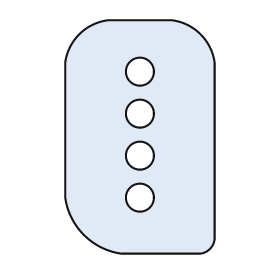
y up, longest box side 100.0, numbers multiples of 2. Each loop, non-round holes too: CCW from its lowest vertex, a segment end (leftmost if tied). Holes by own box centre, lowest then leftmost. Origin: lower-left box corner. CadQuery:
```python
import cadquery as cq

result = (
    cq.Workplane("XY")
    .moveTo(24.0, 0.0)
    .lineTo(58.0, 0.0)
    .threePointArc((62.0, 2.0), (64.0, 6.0))
    .lineTo(64.0, 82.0)
    .threePointArc((58.0, 94.0), (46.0, 100.0))
    .lineTo(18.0, 100.0)
    .threePointArc((6.0, 94.0), (0.0, 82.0))
    .lineTo(0.0, 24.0)
    .threePointArc((8.0, 8.0), (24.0, 0.0))
    .close()
    .moveTo(32.0, 24.0)
    .circle(6.0)
    .moveTo(32.0, 42.0)
    .circle(6.0)
    .moveTo(32.0, 60.0)
    .circle(6.0)
    .moveTo(32.0, 78.0)
    .circle(6.0)
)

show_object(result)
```